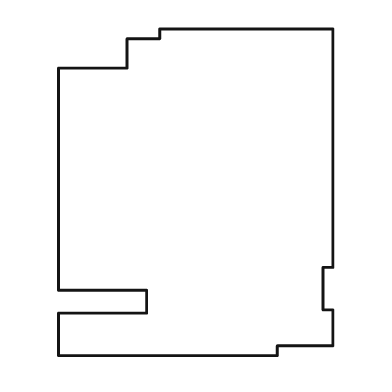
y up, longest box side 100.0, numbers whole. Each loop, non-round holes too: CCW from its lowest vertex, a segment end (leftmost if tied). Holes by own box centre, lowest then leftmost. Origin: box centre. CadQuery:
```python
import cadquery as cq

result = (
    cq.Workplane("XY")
    .moveTo(-42.0, -50.0)
    .lineTo(25.0, -50.0)
    .lineTo(25.0, -47.0)
    .lineTo(42.0, -47.0)
    .lineTo(42.0, -36.0)
    .lineTo(39.0, -36.0)
    .lineTo(39.0, -23.0)
    .lineTo(42.0, -23.0)
    .lineTo(42.0, 50.0)
    .lineTo(-11.0, 50.0)
    .lineTo(-11.0, 47.0)
    .lineTo(-21.0, 47.0)
    .lineTo(-21.0, 38.0)
    .lineTo(-42.0, 38.0)
    .lineTo(-42.0, -30.0)
    .lineTo(-15.0, -30.0)
    .lineTo(-15.0, -37.0)
    .lineTo(-42.0, -37.0)
    .close()
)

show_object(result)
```